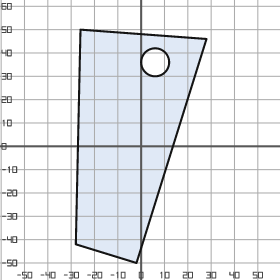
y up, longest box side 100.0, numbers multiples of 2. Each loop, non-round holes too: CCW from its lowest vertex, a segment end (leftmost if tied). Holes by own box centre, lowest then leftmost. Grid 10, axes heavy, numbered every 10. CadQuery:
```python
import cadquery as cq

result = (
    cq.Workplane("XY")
    .moveTo(-2.0, -50.0)
    .lineTo(28.0, 46.0)
    .lineTo(-26.0, 50.0)
    .lineTo(-28.0, -42.0)
    .close()
    .moveTo(6.0, 36.0)
    .circle(6.0)
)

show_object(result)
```